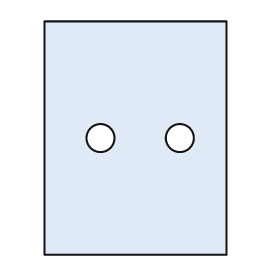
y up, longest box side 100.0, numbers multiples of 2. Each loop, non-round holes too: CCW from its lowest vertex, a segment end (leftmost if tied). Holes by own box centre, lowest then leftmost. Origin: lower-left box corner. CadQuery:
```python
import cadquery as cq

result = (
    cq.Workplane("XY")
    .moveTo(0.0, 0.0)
    .lineTo(78.0, 0.0)
    .lineTo(78.0, 100.0)
    .lineTo(0.0, 100.0)
    .close()
    .moveTo(24.0, 50.0)
    .circle(6.0)
    .moveTo(58.0, 50.0)
    .circle(6.0)
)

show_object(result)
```